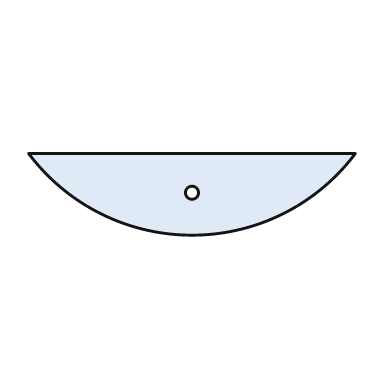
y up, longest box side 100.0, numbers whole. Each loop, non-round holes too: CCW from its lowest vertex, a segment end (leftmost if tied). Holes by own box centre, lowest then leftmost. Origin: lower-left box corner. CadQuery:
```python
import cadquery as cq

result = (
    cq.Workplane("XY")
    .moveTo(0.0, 25.0)
    .threePointArc((50.0, 0.0), (100.0, 25.0))
    .close()
    .moveTo(50.0, 13.0)
    .circle(2.0)
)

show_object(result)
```